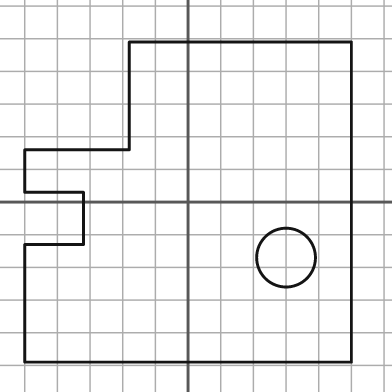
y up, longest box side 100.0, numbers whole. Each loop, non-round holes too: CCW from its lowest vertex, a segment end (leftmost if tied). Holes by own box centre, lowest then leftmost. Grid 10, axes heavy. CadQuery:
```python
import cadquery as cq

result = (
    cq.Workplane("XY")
    .moveTo(-50.0, -49.0)
    .lineTo(50.0, -49.0)
    .lineTo(50.0, 49.0)
    .lineTo(-18.0, 49.0)
    .lineTo(-18.0, 16.0)
    .lineTo(-50.0, 16.0)
    .lineTo(-50.0, 3.0)
    .lineTo(-32.0, 3.0)
    .lineTo(-32.0, -13.0)
    .lineTo(-50.0, -13.0)
    .close()
    .moveTo(30.0, -17.0)
    .circle(9.0)
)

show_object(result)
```